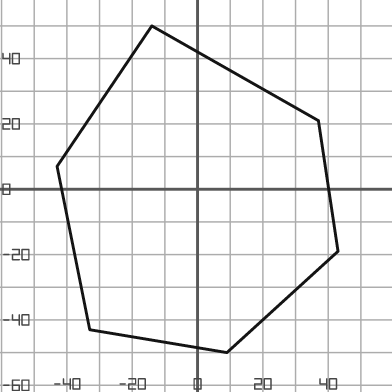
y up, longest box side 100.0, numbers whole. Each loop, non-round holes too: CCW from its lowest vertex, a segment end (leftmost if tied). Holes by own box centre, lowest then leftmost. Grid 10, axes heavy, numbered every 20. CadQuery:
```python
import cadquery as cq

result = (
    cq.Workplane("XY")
    .moveTo(9.0, -50.0)
    .lineTo(43.0, -19.0)
    .lineTo(37.0, 21.0)
    .lineTo(-14.0, 50.0)
    .lineTo(-43.0, 7.0)
    .lineTo(-33.0, -43.0)
    .close()
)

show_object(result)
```